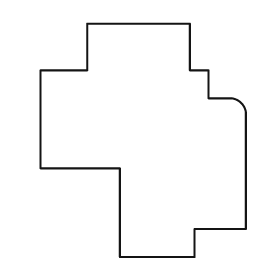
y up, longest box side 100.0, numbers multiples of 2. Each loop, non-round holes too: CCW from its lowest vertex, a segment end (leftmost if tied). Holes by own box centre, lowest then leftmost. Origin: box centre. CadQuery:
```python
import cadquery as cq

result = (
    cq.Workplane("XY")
    .moveTo(-10.0, -50.0)
    .lineTo(22.0, -50.0)
    .lineTo(22.0, -38.0)
    .lineTo(44.0, -38.0)
    .lineTo(44.0, 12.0)
    .threePointArc((42.0, 16.0), (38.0, 18.0))
    .lineTo(28.0, 18.0)
    .lineTo(28.0, 30.0)
    .lineTo(20.0, 30.0)
    .lineTo(20.0, 50.0)
    .lineTo(-24.0, 50.0)
    .lineTo(-24.0, 30.0)
    .lineTo(-44.0, 30.0)
    .lineTo(-44.0, -12.0)
    .lineTo(-10.0, -12.0)
    .close()
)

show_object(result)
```